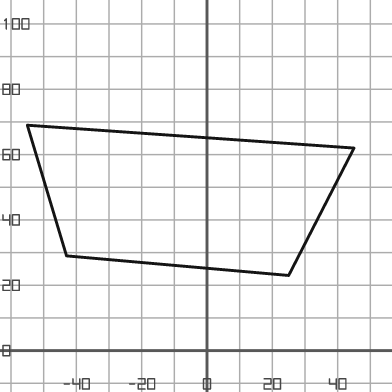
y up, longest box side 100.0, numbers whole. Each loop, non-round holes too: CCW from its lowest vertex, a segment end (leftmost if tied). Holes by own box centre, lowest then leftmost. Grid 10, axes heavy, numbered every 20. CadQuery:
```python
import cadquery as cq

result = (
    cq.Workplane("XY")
    .moveTo(25.0, 23.0)
    .lineTo(45.0, 62.0)
    .lineTo(-55.0, 69.0)
    .lineTo(-43.0, 29.0)
    .close()
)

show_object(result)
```